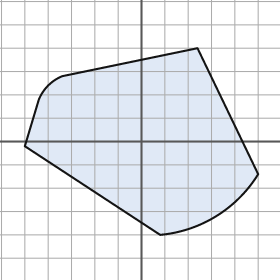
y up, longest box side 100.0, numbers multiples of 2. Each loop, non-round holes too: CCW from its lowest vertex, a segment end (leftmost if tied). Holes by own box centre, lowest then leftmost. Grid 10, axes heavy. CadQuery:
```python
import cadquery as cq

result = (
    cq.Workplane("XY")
    .moveTo(8.0, -40.0)
    .threePointArc((32.0, -32.0), (50.0, -14.0))
    .lineTo(24.0, 40.0)
    .lineTo(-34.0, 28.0)
    .threePointArc((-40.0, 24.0), (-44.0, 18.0))
    .lineTo(-50.0, -2.0)
    .close()
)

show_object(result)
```